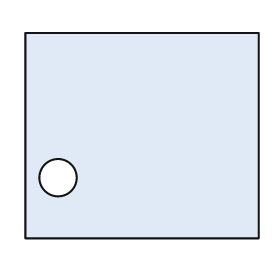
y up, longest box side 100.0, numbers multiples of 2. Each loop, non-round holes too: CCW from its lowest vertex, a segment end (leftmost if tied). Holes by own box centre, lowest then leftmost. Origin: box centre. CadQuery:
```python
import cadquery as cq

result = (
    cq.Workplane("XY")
    .moveTo(-50.0, -44.0)
    .lineTo(50.0, -44.0)
    .lineTo(50.0, 44.0)
    .lineTo(-50.0, 44.0)
    .close()
    .moveTo(-36.0, -18.0)
    .circle(8.0)
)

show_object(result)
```